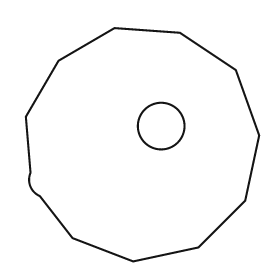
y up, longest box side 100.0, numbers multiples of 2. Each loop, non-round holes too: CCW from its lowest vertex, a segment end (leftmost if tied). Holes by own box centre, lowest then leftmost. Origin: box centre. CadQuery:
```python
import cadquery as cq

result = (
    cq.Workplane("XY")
    .moveTo(-4.0, -50.0)
    .lineTo(24.0, -44.0)
    .lineTo(44.0, -24.0)
    .lineTo(50.0, 4.0)
    .lineTo(40.0, 32.0)
    .lineTo(16.0, 48.0)
    .lineTo(-12.0, 50.0)
    .lineTo(-36.0, 36.0)
    .lineTo(-50.0, 12.0)
    .lineTo(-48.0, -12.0)
    .threePointArc((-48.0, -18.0), (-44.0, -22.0))
    .lineTo(-30.0, -40.0)
    .close()
    .moveTo(8.0, 8.0)
    .circle(10.0)
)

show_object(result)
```